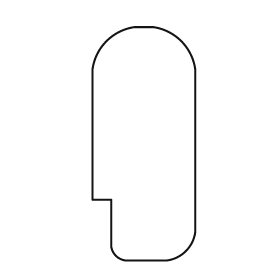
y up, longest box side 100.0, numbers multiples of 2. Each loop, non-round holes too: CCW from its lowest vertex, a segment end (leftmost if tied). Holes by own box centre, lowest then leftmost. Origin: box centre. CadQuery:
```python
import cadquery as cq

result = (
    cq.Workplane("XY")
    .moveTo(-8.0, -50.0)
    .lineTo(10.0, -50.0)
    .threePointArc((18.0, -46.0), (22.0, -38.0))
    .lineTo(22.0, 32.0)
    .threePointArc((16.0, 44.0), (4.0, 50.0))
    .lineTo(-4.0, 50.0)
    .threePointArc((-16.0, 44.0), (-22.0, 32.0))
    .lineTo(-22.0, -24.0)
    .lineTo(-14.0, -24.0)
    .lineTo(-14.0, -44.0)
    .threePointArc((-12.0, -48.0), (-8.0, -50.0))
    .close()
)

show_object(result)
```